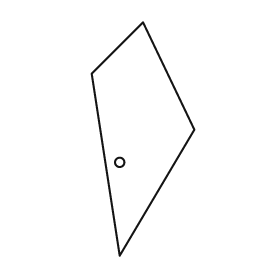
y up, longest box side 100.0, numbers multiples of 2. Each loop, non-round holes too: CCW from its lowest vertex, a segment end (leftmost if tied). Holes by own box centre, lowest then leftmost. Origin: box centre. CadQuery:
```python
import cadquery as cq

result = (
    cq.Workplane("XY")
    .moveTo(-10.0, -50.0)
    .lineTo(22.0, 4.0)
    .lineTo(0.0, 50.0)
    .lineTo(-22.0, 28.0)
    .close()
    .moveTo(-10.0, -10.0)
    .circle(2.0)
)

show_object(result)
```